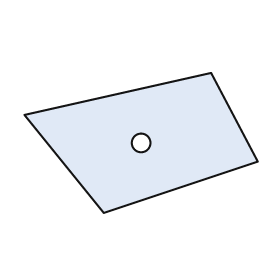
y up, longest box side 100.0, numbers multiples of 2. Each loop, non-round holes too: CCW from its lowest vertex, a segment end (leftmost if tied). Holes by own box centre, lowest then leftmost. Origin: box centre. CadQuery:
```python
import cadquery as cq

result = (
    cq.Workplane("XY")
    .moveTo(-16.0, -30.0)
    .lineTo(50.0, -8.0)
    .lineTo(30.0, 30.0)
    .lineTo(-50.0, 12.0)
    .close()
    .moveTo(0.0, 0.0)
    .circle(4.0)
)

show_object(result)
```